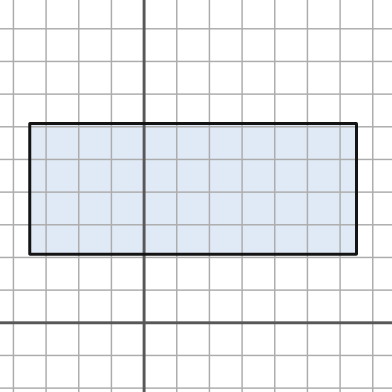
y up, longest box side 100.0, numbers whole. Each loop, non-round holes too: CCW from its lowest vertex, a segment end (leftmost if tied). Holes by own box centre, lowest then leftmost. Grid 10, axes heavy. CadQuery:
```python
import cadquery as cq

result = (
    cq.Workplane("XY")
    .moveTo(-35.0, 21.0)
    .lineTo(65.0, 21.0)
    .lineTo(65.0, 61.0)
    .lineTo(-35.0, 61.0)
    .close()
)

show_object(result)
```